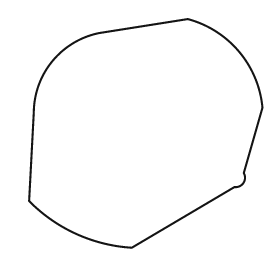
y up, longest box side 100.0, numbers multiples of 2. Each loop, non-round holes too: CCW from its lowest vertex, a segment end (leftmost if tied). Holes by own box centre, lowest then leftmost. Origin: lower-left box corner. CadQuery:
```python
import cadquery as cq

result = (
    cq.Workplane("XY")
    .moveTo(44.0, 0.0)
    .lineTo(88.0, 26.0)
    .threePointArc((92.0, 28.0), (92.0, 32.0))
    .lineTo(100.0, 60.0)
    .threePointArc((90.0, 84.0), (68.0, 98.0))
    .lineTo(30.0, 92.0)
    .threePointArc((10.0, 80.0), (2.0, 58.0))
    .lineTo(0.0, 20.0)
    .threePointArc((20.0, 6.0), (44.0, 0.0))
    .close()
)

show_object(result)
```